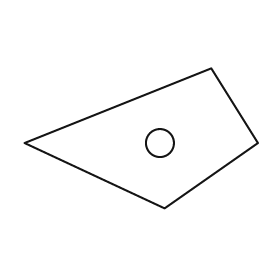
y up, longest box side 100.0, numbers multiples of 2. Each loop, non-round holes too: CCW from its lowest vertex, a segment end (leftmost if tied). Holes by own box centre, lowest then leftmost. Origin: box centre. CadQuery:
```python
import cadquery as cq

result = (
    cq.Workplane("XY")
    .moveTo(10.0, -30.0)
    .lineTo(50.0, -2.0)
    .lineTo(30.0, 30.0)
    .lineTo(-50.0, -2.0)
    .close()
    .moveTo(8.0, -2.0)
    .circle(6.0)
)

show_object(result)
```